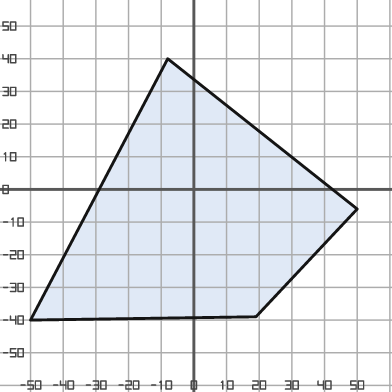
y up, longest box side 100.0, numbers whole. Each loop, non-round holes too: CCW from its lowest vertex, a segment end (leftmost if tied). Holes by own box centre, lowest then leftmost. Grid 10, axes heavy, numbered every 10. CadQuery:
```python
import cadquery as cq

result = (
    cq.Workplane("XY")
    .moveTo(-50.0, -40.0)
    .lineTo(19.0, -39.0)
    .lineTo(50.0, -6.0)
    .lineTo(-8.0, 40.0)
    .close()
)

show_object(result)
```